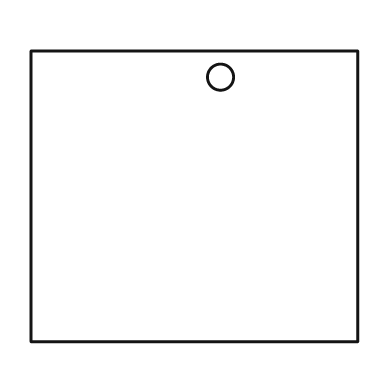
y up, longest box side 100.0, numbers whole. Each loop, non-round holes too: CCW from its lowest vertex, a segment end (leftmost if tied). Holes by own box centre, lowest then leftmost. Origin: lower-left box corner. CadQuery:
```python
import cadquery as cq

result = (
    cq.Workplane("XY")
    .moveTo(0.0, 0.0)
    .lineTo(100.0, 0.0)
    .lineTo(100.0, 89.0)
    .lineTo(0.0, 89.0)
    .close()
    .moveTo(58.0, 81.0)
    .circle(4.0)
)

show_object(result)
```